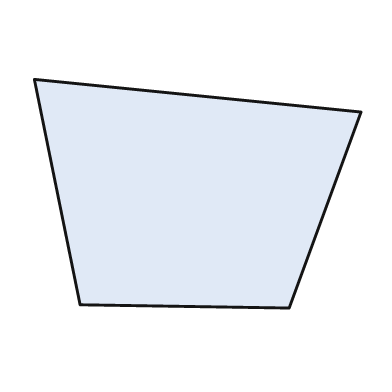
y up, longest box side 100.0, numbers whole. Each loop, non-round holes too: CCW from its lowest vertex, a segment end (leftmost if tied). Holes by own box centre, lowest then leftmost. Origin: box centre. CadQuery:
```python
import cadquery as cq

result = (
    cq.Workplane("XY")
    .moveTo(28.0, -35.0)
    .lineTo(50.0, 25.0)
    .lineTo(-50.0, 35.0)
    .lineTo(-36.0, -34.0)
    .close()
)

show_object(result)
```